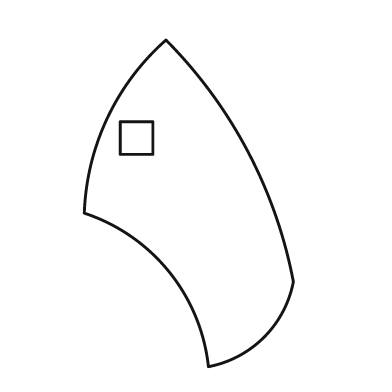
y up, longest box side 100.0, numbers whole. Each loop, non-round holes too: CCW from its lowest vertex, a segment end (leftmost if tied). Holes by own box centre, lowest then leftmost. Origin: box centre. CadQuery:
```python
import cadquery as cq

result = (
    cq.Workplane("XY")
    .moveTo(6.0, -50.0)
    .threePointArc((23.0, -41.0), (32.0, -24.0))
    .threePointArc((18.0, 16.0), (-7.0, 50.0))
    .threePointArc((-25.0, 26.0), (-32.0, -3.0))
    .threePointArc((-6.0, -21.0), (6.0, -50.0))
    .close()
    .moveTo(-21.0, 15.0)
    .lineTo(-11.0, 15.0)
    .lineTo(-11.0, 25.0)
    .lineTo(-21.0, 25.0)
    .close()
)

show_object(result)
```